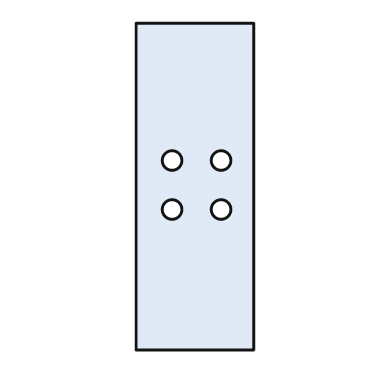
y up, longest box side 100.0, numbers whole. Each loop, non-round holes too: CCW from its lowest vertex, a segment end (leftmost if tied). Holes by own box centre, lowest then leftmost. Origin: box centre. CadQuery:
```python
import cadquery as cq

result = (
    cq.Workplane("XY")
    .moveTo(-18.0, -50.0)
    .lineTo(18.0, -50.0)
    .lineTo(18.0, 50.0)
    .lineTo(-18.0, 50.0)
    .close()
    .moveTo(-7.0, -7.0)
    .circle(3.0)
    .moveTo(8.0, -7.0)
    .circle(3.0)
    .moveTo(-7.0, 8.0)
    .circle(3.0)
    .moveTo(8.0, 8.0)
    .circle(3.0)
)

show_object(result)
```